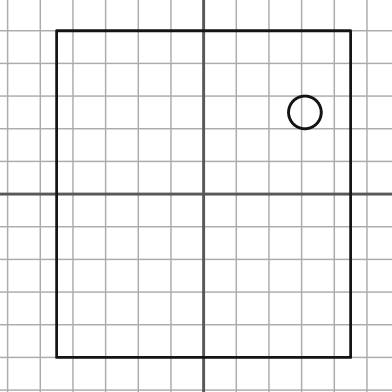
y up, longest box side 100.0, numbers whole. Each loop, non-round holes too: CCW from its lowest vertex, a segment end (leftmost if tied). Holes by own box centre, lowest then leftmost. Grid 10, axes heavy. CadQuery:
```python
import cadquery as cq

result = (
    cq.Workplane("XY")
    .moveTo(-45.0, -50.0)
    .lineTo(45.0, -50.0)
    .lineTo(45.0, 50.0)
    .lineTo(-45.0, 50.0)
    .close()
    .moveTo(31.0, 25.0)
    .circle(5.0)
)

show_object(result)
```